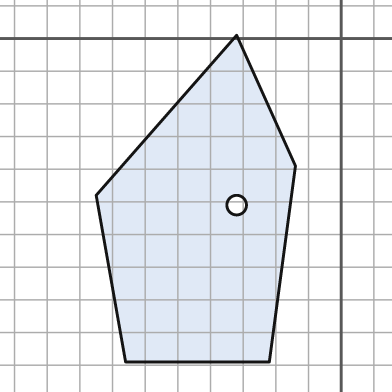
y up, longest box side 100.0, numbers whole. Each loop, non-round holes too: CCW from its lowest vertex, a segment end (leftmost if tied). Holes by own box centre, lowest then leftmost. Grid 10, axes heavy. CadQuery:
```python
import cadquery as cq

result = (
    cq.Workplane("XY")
    .moveTo(-66.0, -99.0)
    .lineTo(-22.0, -99.0)
    .lineTo(-14.0, -39.0)
    .lineTo(-32.0, 1.0)
    .lineTo(-75.0, -48.0)
    .close()
    .moveTo(-32.0, -51.0)
    .circle(3.0)
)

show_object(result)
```